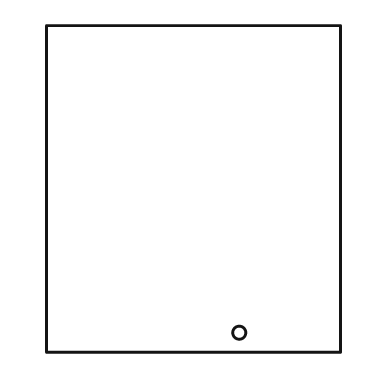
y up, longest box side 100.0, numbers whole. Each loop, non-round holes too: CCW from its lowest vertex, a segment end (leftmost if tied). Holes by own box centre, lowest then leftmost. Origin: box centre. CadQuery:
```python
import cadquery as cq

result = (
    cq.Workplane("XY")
    .moveTo(-45.0, -50.0)
    .lineTo(45.0, -50.0)
    .lineTo(45.0, 50.0)
    .lineTo(-45.0, 50.0)
    .close()
    .moveTo(14.0, -44.0)
    .circle(2.0)
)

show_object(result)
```